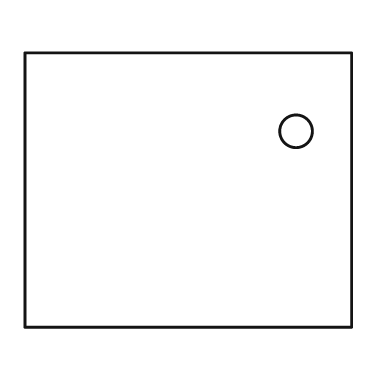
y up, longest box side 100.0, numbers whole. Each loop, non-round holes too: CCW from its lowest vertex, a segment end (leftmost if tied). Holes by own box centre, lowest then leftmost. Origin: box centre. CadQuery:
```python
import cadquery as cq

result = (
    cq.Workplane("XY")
    .moveTo(-50.0, -42.0)
    .lineTo(50.0, -42.0)
    .lineTo(50.0, 42.0)
    .lineTo(-50.0, 42.0)
    .close()
    .moveTo(33.0, 18.0)
    .circle(5.0)
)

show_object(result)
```